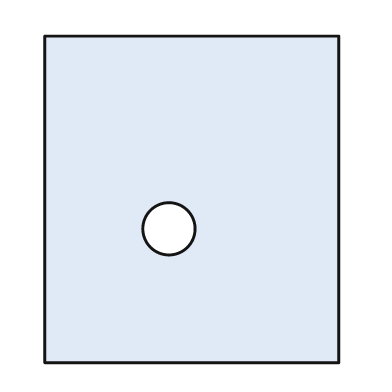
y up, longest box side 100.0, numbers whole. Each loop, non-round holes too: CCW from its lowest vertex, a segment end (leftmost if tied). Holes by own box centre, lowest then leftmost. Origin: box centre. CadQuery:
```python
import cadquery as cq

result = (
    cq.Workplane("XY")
    .moveTo(-45.0, -50.0)
    .lineTo(45.0, -50.0)
    .lineTo(45.0, 50.0)
    .lineTo(-45.0, 50.0)
    .close()
    .moveTo(-7.0, -9.0)
    .circle(8.0)
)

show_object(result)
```